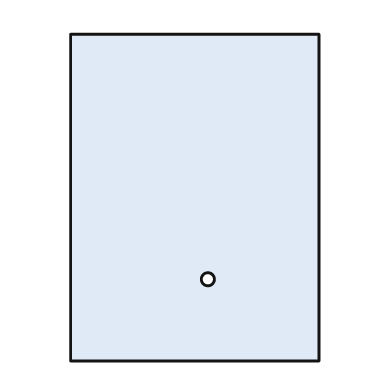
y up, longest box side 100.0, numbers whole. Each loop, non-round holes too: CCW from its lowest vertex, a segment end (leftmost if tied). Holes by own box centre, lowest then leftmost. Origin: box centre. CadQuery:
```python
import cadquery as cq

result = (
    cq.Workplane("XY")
    .moveTo(-38.0, -50.0)
    .lineTo(38.0, -50.0)
    .lineTo(38.0, 50.0)
    .lineTo(-38.0, 50.0)
    .close()
    .moveTo(4.0, -25.0)
    .circle(2.0)
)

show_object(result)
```